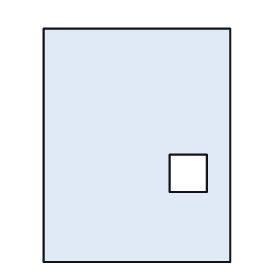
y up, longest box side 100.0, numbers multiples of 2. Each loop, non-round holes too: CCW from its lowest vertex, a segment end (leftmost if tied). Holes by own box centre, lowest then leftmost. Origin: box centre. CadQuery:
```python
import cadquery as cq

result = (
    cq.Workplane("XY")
    .moveTo(-40.0, -50.0)
    .lineTo(40.0, -50.0)
    .lineTo(40.0, 50.0)
    .lineTo(-40.0, 50.0)
    .close()
    .moveTo(14.0, -20.0)
    .lineTo(30.0, -20.0)
    .lineTo(30.0, -4.0)
    .lineTo(14.0, -4.0)
    .close()
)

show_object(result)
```